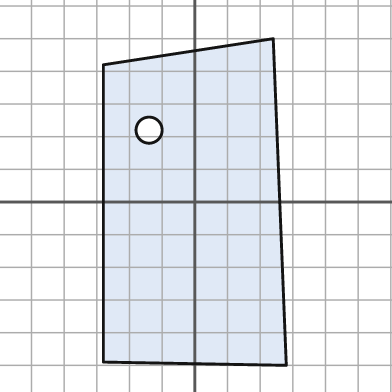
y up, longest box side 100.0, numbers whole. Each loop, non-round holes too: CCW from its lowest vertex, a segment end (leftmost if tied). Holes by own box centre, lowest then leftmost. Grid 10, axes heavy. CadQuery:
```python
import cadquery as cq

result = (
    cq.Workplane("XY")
    .moveTo(28.0, -50.0)
    .lineTo(24.0, 50.0)
    .lineTo(-28.0, 42.0)
    .lineTo(-28.0, -49.0)
    .close()
    .moveTo(-14.0, 22.0)
    .circle(4.0)
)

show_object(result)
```